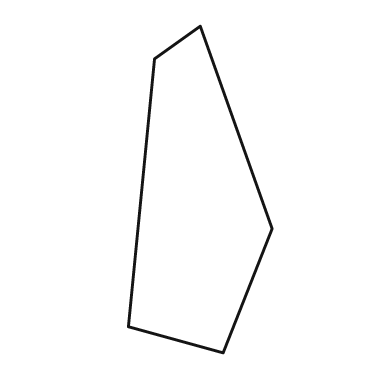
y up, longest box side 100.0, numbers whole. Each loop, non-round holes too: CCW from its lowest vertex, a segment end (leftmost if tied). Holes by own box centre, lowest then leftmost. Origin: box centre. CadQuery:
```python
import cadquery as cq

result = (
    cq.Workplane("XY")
    .moveTo(7.0, -50.0)
    .lineTo(22.0, -12.0)
    .lineTo(0.0, 50.0)
    .lineTo(-14.0, 40.0)
    .lineTo(-22.0, -42.0)
    .close()
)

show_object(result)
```